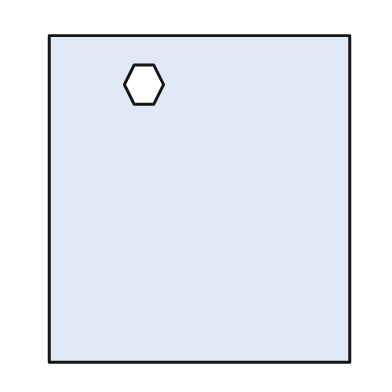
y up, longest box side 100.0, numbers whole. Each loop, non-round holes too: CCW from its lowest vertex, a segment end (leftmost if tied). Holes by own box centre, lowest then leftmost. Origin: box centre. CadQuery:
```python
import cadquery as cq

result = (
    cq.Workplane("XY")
    .moveTo(-46.0, -50.0)
    .lineTo(46.0, -50.0)
    .lineTo(46.0, 50.0)
    .lineTo(-46.0, 50.0)
    .close()
    .moveTo(-20.0, 29.0)
    .lineTo(-14.0, 29.0)
    .lineTo(-11.0, 35.0)
    .lineTo(-14.0, 41.0)
    .lineTo(-20.0, 41.0)
    .lineTo(-23.0, 35.0)
    .close()
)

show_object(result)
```